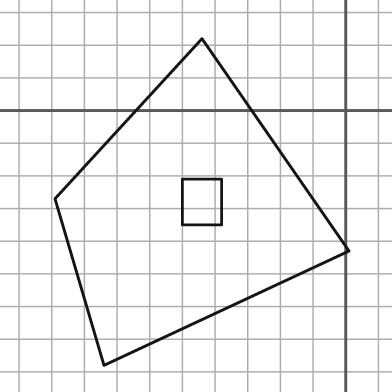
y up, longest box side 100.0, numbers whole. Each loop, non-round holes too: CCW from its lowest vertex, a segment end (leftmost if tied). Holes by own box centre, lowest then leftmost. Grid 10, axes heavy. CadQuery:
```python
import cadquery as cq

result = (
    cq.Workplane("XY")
    .moveTo(-74.0, -78.0)
    .lineTo(1.0, -43.0)
    .lineTo(-44.0, 22.0)
    .lineTo(-89.0, -27.0)
    .close()
    .moveTo(-50.0, -35.0)
    .lineTo(-38.0, -35.0)
    .lineTo(-38.0, -21.0)
    .lineTo(-50.0, -21.0)
    .close()
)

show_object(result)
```